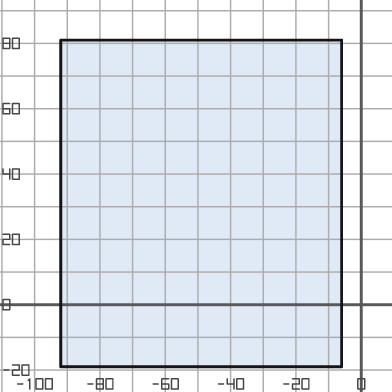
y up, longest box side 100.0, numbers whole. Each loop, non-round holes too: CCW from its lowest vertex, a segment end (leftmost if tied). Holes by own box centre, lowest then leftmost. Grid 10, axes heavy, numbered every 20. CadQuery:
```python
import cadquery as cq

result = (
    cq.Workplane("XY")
    .moveTo(-92.0, -19.0)
    .lineTo(-6.0, -19.0)
    .lineTo(-6.0, 81.0)
    .lineTo(-92.0, 81.0)
    .close()
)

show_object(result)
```